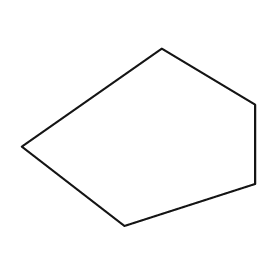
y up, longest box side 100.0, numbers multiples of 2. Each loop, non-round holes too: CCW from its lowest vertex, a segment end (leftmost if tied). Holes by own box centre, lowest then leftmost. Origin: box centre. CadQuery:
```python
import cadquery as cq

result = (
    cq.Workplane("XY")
    .moveTo(-6.0, -38.0)
    .lineTo(50.0, -20.0)
    .lineTo(50.0, 14.0)
    .lineTo(10.0, 38.0)
    .lineTo(-50.0, -4.0)
    .close()
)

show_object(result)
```